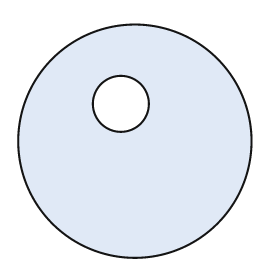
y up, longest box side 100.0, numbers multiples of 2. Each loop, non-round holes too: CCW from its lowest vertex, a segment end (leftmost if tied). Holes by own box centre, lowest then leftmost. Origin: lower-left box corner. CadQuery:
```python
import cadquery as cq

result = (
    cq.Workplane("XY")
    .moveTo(50.0, 50.0)
    .circle(50.0)
    .moveTo(44.0, 66.0)
    .circle(12.0)
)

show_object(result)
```